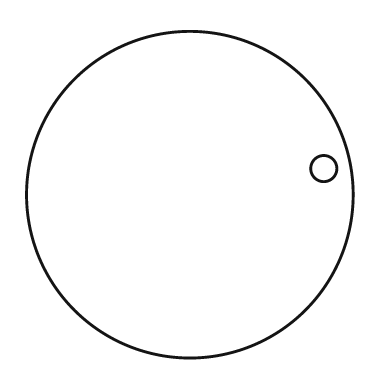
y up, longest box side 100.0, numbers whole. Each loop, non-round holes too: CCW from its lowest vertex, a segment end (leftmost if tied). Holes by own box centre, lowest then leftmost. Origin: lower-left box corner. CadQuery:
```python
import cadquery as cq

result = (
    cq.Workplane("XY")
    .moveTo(50.0, 50.0)
    .circle(50.0)
    .moveTo(91.0, 58.0)
    .circle(4.0)
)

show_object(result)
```